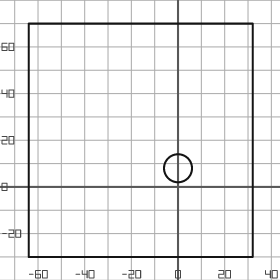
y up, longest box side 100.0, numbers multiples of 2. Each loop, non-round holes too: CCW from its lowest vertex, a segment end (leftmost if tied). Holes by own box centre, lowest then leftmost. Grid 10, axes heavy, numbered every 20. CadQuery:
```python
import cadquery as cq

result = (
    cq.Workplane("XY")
    .moveTo(-64.0, -30.0)
    .lineTo(32.0, -30.0)
    .lineTo(32.0, 70.0)
    .lineTo(-64.0, 70.0)
    .close()
    .moveTo(0.0, 8.0)
    .circle(6.0)
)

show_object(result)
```